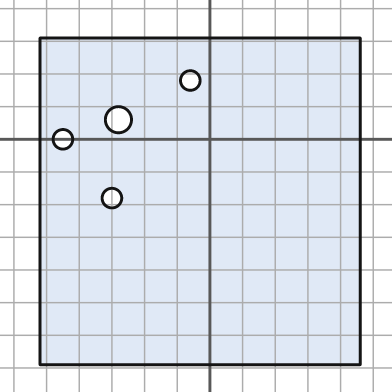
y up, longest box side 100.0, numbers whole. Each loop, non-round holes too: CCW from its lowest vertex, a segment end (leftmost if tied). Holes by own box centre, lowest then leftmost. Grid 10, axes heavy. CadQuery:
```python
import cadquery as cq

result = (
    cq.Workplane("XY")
    .moveTo(-52.0, -69.0)
    .lineTo(46.0, -69.0)
    .lineTo(46.0, 31.0)
    .lineTo(-52.0, 31.0)
    .close()
    .moveTo(-30.0, -18.0)
    .circle(3.0)
    .moveTo(-45.0, 0.0)
    .circle(3.0)
    .moveTo(-28.0, 6.0)
    .circle(4.0)
    .moveTo(-6.0, 18.0)
    .circle(3.0)
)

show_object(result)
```